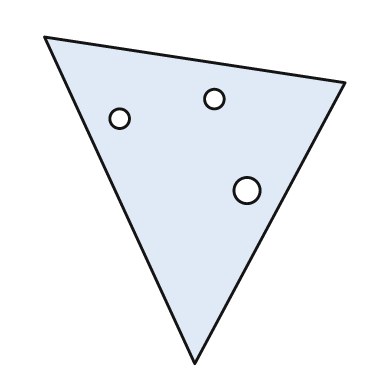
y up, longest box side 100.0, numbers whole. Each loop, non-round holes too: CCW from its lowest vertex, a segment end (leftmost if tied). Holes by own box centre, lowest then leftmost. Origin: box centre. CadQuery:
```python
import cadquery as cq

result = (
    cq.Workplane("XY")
    .moveTo(0.0, -50.0)
    .lineTo(46.0, 36.0)
    .lineTo(-46.0, 50.0)
    .close()
    .moveTo(16.0, 3.0)
    .circle(4.0)
    .moveTo(-23.0, 25.0)
    .circle(3.0)
    .moveTo(6.0, 31.0)
    .circle(3.0)
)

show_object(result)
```